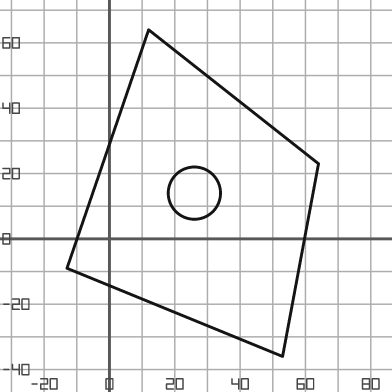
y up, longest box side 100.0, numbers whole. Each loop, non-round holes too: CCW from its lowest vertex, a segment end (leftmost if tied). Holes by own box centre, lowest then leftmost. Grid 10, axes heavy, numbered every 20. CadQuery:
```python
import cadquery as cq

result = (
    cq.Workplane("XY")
    .moveTo(53.0, -36.0)
    .lineTo(64.0, 23.0)
    .lineTo(12.0, 64.0)
    .lineTo(-13.0, -9.0)
    .close()
    .moveTo(26.0, 14.0)
    .circle(8.0)
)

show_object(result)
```